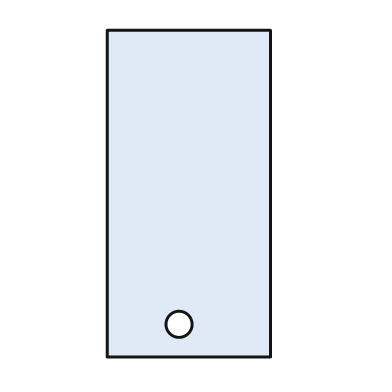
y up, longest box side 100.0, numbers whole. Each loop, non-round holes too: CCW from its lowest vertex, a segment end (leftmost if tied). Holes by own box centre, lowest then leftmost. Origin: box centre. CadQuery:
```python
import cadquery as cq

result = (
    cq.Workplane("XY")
    .moveTo(-25.0, -50.0)
    .lineTo(25.0, -50.0)
    .lineTo(25.0, 50.0)
    .lineTo(-25.0, 50.0)
    .close()
    .moveTo(-3.0, -40.0)
    .circle(4.0)
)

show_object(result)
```